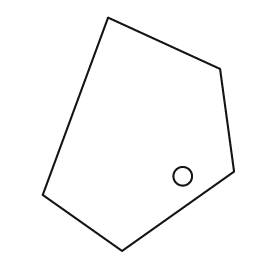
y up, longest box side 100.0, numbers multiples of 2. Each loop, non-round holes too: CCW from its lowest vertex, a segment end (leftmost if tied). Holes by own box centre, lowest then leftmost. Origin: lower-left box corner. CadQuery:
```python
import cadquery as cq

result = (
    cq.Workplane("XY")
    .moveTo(34.0, 0.0)
    .lineTo(82.0, 34.0)
    .lineTo(76.0, 78.0)
    .lineTo(28.0, 100.0)
    .lineTo(0.0, 24.0)
    .close()
    .moveTo(60.0, 32.0)
    .circle(4.0)
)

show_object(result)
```